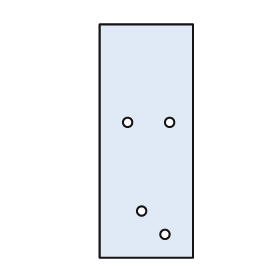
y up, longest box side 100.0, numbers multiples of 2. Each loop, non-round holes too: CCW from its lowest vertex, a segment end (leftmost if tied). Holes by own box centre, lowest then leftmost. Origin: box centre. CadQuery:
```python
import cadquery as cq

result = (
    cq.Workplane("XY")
    .moveTo(-20.0, -50.0)
    .lineTo(20.0, -50.0)
    .lineTo(20.0, 50.0)
    .lineTo(-20.0, 50.0)
    .close()
    .moveTo(8.0, -40.0)
    .circle(2.0)
    .moveTo(-2.0, -30.0)
    .circle(2.0)
    .moveTo(-8.0, 8.0)
    .circle(2.0)
    .moveTo(10.0, 8.0)
    .circle(2.0)
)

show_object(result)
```